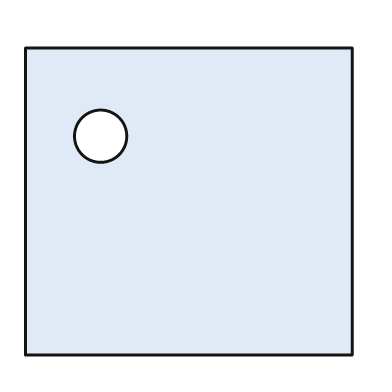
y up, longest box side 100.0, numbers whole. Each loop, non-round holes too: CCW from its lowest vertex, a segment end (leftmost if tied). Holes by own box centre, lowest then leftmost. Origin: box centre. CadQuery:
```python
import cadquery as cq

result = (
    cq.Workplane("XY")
    .moveTo(-50.0, -47.0)
    .lineTo(50.0, -47.0)
    .lineTo(50.0, 47.0)
    .lineTo(-50.0, 47.0)
    .close()
    .moveTo(-27.0, 20.0)
    .circle(8.0)
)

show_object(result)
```